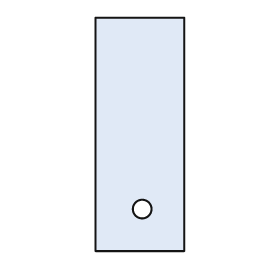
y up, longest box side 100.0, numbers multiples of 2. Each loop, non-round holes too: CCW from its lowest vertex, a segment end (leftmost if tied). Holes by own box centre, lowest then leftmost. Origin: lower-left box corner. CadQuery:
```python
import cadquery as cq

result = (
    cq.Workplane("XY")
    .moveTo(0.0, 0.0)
    .lineTo(38.0, 0.0)
    .lineTo(38.0, 100.0)
    .lineTo(0.0, 100.0)
    .close()
    .moveTo(20.0, 18.0)
    .circle(4.0)
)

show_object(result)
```